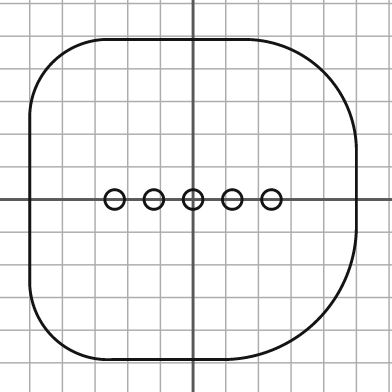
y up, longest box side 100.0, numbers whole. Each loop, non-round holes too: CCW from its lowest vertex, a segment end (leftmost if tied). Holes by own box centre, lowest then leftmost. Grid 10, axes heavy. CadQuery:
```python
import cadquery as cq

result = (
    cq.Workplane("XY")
    .moveTo(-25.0, -49.0)
    .lineTo(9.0, -49.0)
    .threePointArc((38.0, -37.0), (50.0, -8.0))
    .lineTo(50.0, 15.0)
    .threePointArc((40.0, 39.0), (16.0, 49.0))
    .lineTo(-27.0, 49.0)
    .threePointArc((-43.0, 42.0), (-50.0, 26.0))
    .lineTo(-50.0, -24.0)
    .threePointArc((-43.0, -42.0), (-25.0, -49.0))
    .close()
    .moveTo(-24.0, 0.0)
    .circle(3.0)
    .moveTo(-12.0, 0.0)
    .circle(3.0)
    .moveTo(0.0, 0.0)
    .circle(3.0)
    .moveTo(12.0, 0.0)
    .circle(3.0)
    .moveTo(24.0, 0.0)
    .circle(3.0)
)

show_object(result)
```